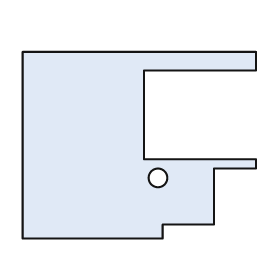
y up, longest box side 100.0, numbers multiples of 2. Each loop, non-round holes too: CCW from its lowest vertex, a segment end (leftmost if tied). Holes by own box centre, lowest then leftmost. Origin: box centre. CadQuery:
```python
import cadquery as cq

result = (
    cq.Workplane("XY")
    .moveTo(-50.0, -40.0)
    .lineTo(10.0, -40.0)
    .lineTo(10.0, -34.0)
    .lineTo(32.0, -34.0)
    .lineTo(32.0, -10.0)
    .lineTo(50.0, -10.0)
    .lineTo(50.0, -6.0)
    .lineTo(2.0, -6.0)
    .lineTo(2.0, 32.0)
    .lineTo(50.0, 32.0)
    .lineTo(50.0, 40.0)
    .lineTo(-50.0, 40.0)
    .close()
    .moveTo(8.0, -14.0)
    .circle(4.0)
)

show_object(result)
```